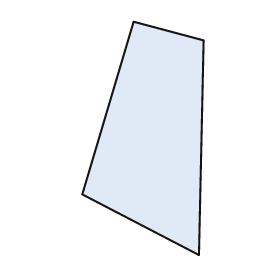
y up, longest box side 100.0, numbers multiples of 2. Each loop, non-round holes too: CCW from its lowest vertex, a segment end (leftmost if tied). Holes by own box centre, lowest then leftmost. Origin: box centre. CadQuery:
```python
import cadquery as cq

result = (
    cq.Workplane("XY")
    .moveTo(24.0, -50.0)
    .lineTo(26.0, 42.0)
    .lineTo(-4.0, 50.0)
    .lineTo(-26.0, -24.0)
    .close()
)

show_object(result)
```